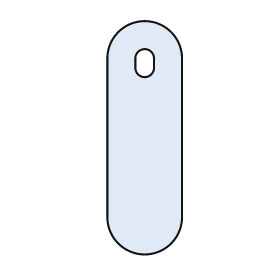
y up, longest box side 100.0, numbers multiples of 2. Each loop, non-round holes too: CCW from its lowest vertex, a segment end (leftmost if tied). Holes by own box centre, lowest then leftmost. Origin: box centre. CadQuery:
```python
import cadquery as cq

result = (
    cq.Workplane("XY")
    .moveTo(-16.0, -34.0)
    .threePointArc((0.0, -50.0), (16.0, -34.0))
    .lineTo(16.0, 34.0)
    .threePointArc((0.0, 50.0), (-16.0, 34.0))
    .close()
    .moveTo(-4.0, 30.0)
    .threePointArc((0.0, 26.0), (4.0, 30.0))
    .lineTo(4.0, 34.0)
    .threePointArc((0.0, 38.0), (-4.0, 34.0))
    .close()
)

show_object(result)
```